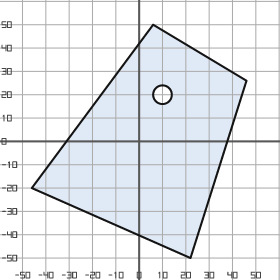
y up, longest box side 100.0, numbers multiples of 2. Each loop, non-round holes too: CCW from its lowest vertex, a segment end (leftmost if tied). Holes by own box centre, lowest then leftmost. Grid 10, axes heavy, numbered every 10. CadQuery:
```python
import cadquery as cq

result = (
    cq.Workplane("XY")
    .moveTo(22.0, -50.0)
    .lineTo(46.0, 26.0)
    .lineTo(6.0, 50.0)
    .lineTo(-46.0, -20.0)
    .close()
    .moveTo(10.0, 20.0)
    .circle(4.0)
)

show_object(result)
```